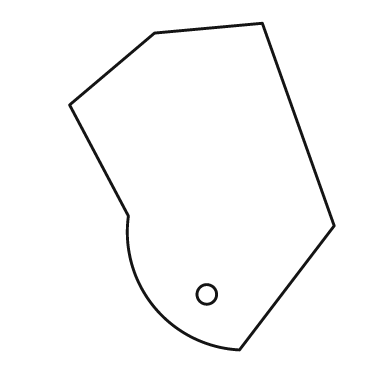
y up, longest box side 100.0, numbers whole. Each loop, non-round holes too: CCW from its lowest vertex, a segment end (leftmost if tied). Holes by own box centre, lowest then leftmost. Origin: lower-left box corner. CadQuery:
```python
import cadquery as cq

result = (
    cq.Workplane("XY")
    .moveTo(52.0, 0.0)
    .lineTo(81.0, 38.0)
    .lineTo(59.0, 100.0)
    .lineTo(26.0, 97.0)
    .lineTo(0.0, 75.0)
    .lineTo(18.0, 41.0)
    .threePointArc((26.0, 13.0), (52.0, 0.0))
    .close()
    .moveTo(42.0, 17.0)
    .circle(3.0)
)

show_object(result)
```